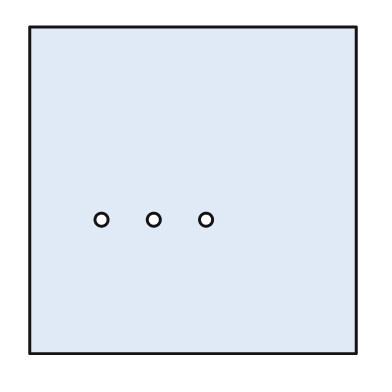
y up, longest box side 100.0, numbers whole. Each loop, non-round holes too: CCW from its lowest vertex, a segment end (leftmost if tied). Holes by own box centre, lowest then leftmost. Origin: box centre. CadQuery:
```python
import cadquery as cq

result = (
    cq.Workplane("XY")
    .moveTo(-50.0, -50.0)
    .lineTo(50.0, -50.0)
    .lineTo(50.0, 50.0)
    .lineTo(-50.0, 50.0)
    .close()
    .moveTo(-28.0, -9.0)
    .circle(2.0)
    .moveTo(-12.0, -9.0)
    .circle(2.0)
    .moveTo(4.0, -9.0)
    .circle(2.0)
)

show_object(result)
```